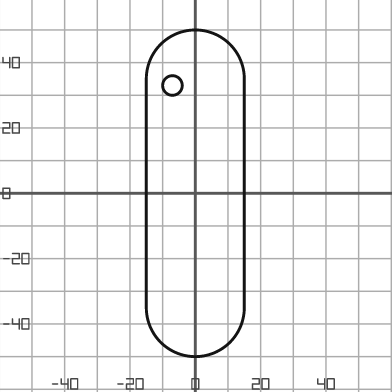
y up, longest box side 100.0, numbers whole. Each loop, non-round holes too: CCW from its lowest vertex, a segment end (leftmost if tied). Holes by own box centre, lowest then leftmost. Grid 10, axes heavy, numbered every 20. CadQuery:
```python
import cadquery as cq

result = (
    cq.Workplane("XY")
    .moveTo(-15.0, -35.0)
    .threePointArc((0.0, -50.0), (15.0, -35.0))
    .lineTo(15.0, 35.0)
    .threePointArc((0.0, 50.0), (-15.0, 35.0))
    .close()
    .moveTo(-7.0, 33.0)
    .circle(3.0)
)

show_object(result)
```